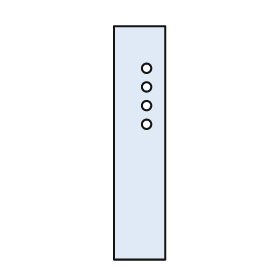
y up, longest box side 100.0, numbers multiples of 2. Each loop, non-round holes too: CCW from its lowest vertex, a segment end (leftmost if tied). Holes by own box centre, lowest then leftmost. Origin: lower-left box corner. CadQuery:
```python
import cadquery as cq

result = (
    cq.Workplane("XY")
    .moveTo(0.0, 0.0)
    .lineTo(22.0, 0.0)
    .lineTo(22.0, 100.0)
    .lineTo(0.0, 100.0)
    .close()
    .moveTo(14.0, 58.0)
    .circle(2.0)
    .moveTo(14.0, 66.0)
    .circle(2.0)
    .moveTo(14.0, 74.0)
    .circle(2.0)
    .moveTo(14.0, 82.0)
    .circle(2.0)
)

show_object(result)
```